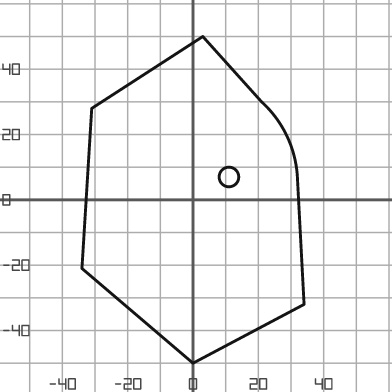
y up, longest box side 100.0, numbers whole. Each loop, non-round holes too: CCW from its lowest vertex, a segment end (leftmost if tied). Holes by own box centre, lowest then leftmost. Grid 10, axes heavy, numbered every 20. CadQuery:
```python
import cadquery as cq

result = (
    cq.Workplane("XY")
    .moveTo(0.0, -50.0)
    .lineTo(34.0, -32.0)
    .lineTo(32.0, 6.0)
    .threePointArc((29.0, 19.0), (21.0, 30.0))
    .lineTo(3.0, 50.0)
    .lineTo(-31.0, 28.0)
    .lineTo(-34.0, -21.0)
    .close()
    .moveTo(11.0, 7.0)
    .circle(3.0)
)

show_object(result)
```